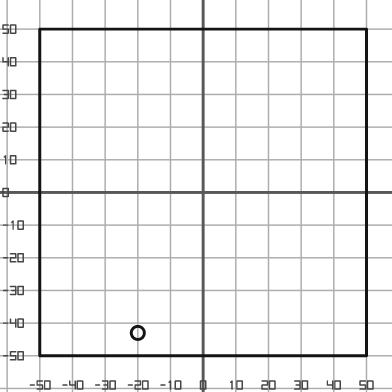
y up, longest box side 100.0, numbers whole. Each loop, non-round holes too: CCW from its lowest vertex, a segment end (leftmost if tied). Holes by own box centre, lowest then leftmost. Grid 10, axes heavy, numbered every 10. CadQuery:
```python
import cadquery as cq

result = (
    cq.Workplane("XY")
    .moveTo(-50.0, -50.0)
    .lineTo(50.0, -50.0)
    .lineTo(50.0, 50.0)
    .lineTo(-50.0, 50.0)
    .close()
    .moveTo(-20.0, -43.0)
    .circle(2.0)
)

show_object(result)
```